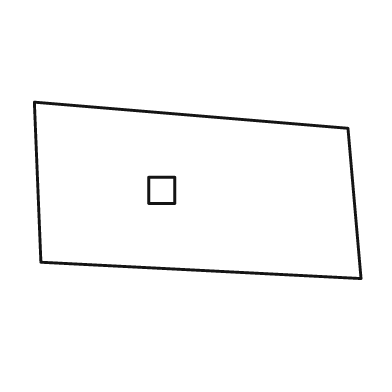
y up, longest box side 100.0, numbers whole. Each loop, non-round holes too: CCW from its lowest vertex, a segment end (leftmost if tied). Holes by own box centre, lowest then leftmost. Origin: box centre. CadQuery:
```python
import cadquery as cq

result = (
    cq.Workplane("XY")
    .moveTo(50.0, -27.0)
    .lineTo(46.0, 19.0)
    .lineTo(-50.0, 27.0)
    .lineTo(-48.0, -22.0)
    .close()
    .moveTo(-15.0, -4.0)
    .lineTo(-7.0, -4.0)
    .lineTo(-7.0, 4.0)
    .lineTo(-15.0, 4.0)
    .close()
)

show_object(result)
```